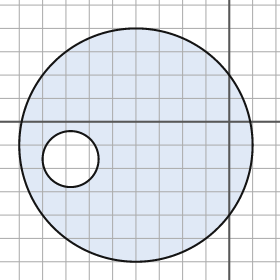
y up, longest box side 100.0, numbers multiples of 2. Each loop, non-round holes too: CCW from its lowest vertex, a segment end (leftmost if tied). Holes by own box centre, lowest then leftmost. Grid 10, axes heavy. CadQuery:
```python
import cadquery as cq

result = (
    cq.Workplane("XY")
    .moveTo(-40.0, -10.0)
    .circle(50.0)
    .moveTo(-68.0, -16.0)
    .circle(12.0)
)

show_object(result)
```